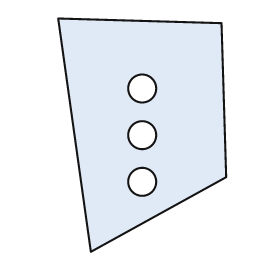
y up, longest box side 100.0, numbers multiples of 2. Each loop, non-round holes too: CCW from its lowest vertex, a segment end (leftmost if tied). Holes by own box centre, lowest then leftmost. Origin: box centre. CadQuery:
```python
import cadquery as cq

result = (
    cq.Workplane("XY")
    .moveTo(-22.0, -50.0)
    .lineTo(36.0, -18.0)
    .lineTo(34.0, 48.0)
    .lineTo(-36.0, 50.0)
    .close()
    .moveTo(0.0, -20.0)
    .circle(6.0)
    .moveTo(0.0, 0.0)
    .circle(6.0)
    .moveTo(0.0, 20.0)
    .circle(6.0)
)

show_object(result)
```